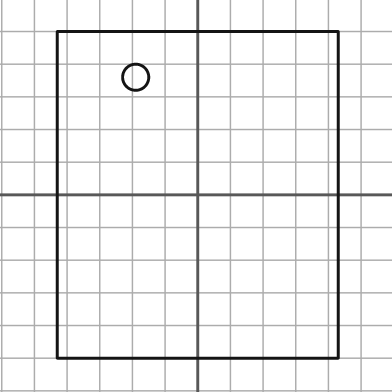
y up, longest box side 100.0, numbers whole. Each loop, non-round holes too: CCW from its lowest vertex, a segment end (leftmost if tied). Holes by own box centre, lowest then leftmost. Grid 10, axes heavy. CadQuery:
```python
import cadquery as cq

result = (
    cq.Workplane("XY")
    .moveTo(-43.0, -50.0)
    .lineTo(43.0, -50.0)
    .lineTo(43.0, 50.0)
    .lineTo(-43.0, 50.0)
    .close()
    .moveTo(-19.0, 36.0)
    .circle(4.0)
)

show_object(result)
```